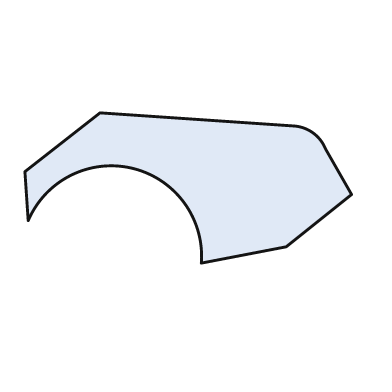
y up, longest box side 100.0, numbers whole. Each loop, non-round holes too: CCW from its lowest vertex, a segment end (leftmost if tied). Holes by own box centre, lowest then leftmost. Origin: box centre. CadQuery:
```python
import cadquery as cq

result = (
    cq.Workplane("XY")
    .moveTo(4.0, -23.0)
    .lineTo(30.0, -18.0)
    .lineTo(50.0, -2.0)
    .lineTo(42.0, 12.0)
    .threePointArc((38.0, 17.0), (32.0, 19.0))
    .lineTo(-27.0, 23.0)
    .lineTo(-50.0, 5.0)
    .lineTo(-49.0, -10.0)
    .threePointArc((-17.0, 6.0), (4.0, -23.0))
    .close()
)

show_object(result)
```